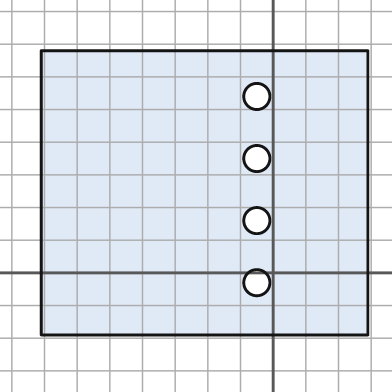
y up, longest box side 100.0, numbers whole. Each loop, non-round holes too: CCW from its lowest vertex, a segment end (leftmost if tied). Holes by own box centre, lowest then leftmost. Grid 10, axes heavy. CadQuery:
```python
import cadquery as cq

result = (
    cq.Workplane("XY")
    .moveTo(-71.0, -19.0)
    .lineTo(29.0, -19.0)
    .lineTo(29.0, 68.0)
    .lineTo(-71.0, 68.0)
    .close()
    .moveTo(-5.0, -3.0)
    .circle(4.0)
    .moveTo(-5.0, 16.0)
    .circle(4.0)
    .moveTo(-5.0, 35.0)
    .circle(4.0)
    .moveTo(-5.0, 54.0)
    .circle(4.0)
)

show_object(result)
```